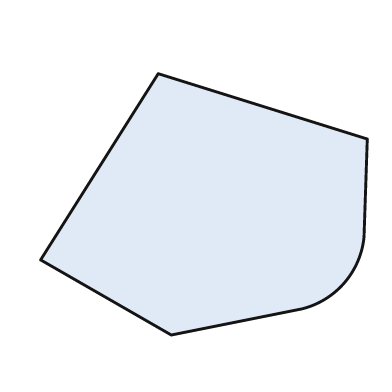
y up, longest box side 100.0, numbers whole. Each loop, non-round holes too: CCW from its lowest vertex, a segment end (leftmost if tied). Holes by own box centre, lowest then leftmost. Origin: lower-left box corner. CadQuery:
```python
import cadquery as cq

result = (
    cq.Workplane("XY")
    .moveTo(40.0, 0.0)
    .lineTo(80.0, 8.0)
    .threePointArc((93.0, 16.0), (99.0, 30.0))
    .lineTo(100.0, 60.0)
    .lineTo(36.0, 80.0)
    .lineTo(0.0, 23.0)
    .close()
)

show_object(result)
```